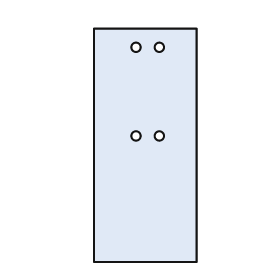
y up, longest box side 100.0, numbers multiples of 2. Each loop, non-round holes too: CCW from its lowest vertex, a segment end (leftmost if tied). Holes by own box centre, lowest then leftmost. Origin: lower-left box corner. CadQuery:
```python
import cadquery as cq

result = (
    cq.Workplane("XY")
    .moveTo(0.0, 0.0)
    .lineTo(44.0, 0.0)
    .lineTo(44.0, 100.0)
    .lineTo(0.0, 100.0)
    .close()
    .moveTo(18.0, 54.0)
    .circle(2.0)
    .moveTo(28.0, 54.0)
    .circle(2.0)
    .moveTo(18.0, 92.0)
    .circle(2.0)
    .moveTo(28.0, 92.0)
    .circle(2.0)
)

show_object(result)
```